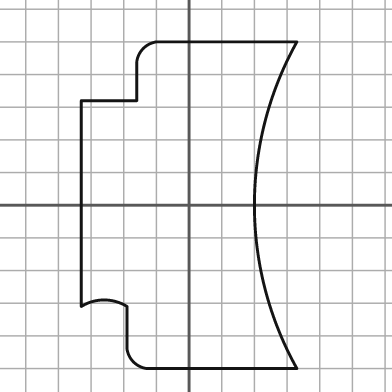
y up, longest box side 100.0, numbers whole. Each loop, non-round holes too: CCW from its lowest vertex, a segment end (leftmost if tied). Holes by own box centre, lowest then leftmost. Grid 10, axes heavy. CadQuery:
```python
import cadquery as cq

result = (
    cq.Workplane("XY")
    .moveTo(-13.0, -50.0)
    .lineTo(33.0, -50.0)
    .threePointArc((20.0, 0.0), (33.0, 50.0))
    .lineTo(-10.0, 50.0)
    .threePointArc((-14.0, 48.0), (-16.0, 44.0))
    .lineTo(-16.0, 32.0)
    .lineTo(-33.0, 32.0)
    .lineTo(-33.0, -31.0)
    .threePointArc((-26.0, -29.0), (-19.0, -31.0))
    .lineTo(-19.0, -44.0)
    .threePointArc((-17.0, -48.0), (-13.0, -50.0))
    .close()
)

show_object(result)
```